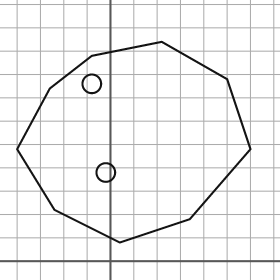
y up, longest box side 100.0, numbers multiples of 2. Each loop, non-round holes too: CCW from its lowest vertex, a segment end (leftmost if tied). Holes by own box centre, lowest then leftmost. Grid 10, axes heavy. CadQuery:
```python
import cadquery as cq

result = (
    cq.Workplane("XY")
    .moveTo(4.0, 8.0)
    .lineTo(34.0, 18.0)
    .lineTo(60.0, 48.0)
    .lineTo(50.0, 78.0)
    .lineTo(22.0, 94.0)
    .lineTo(-8.0, 88.0)
    .lineTo(-26.0, 74.0)
    .lineTo(-40.0, 48.0)
    .lineTo(-24.0, 22.0)
    .close()
    .moveTo(-2.0, 38.0)
    .circle(4.0)
    .moveTo(-8.0, 76.0)
    .circle(4.0)
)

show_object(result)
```